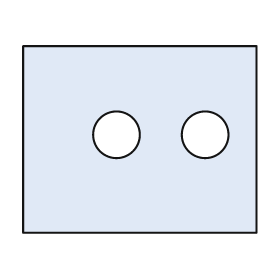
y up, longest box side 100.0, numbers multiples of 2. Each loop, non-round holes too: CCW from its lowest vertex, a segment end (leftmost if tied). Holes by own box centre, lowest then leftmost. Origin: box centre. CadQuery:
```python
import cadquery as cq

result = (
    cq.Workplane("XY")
    .moveTo(-50.0, -40.0)
    .lineTo(50.0, -40.0)
    .lineTo(50.0, 40.0)
    .lineTo(-50.0, 40.0)
    .close()
    .moveTo(-10.0, 2.0)
    .circle(10.0)
    .moveTo(28.0, 2.0)
    .circle(10.0)
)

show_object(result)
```